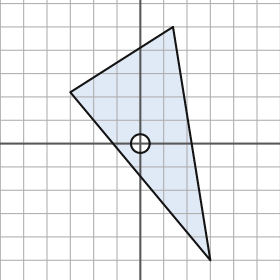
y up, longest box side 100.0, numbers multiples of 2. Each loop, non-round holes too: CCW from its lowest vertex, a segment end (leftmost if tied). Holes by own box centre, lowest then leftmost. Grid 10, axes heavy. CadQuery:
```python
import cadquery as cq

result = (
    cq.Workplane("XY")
    .moveTo(30.0, -50.0)
    .lineTo(14.0, 50.0)
    .lineTo(-30.0, 22.0)
    .close()
    .moveTo(0.0, 0.0)
    .circle(4.0)
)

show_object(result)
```